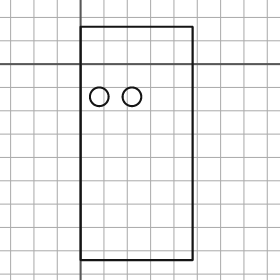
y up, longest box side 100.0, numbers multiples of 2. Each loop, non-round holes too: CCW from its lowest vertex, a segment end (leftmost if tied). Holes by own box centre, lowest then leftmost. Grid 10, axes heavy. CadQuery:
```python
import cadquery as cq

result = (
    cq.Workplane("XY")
    .moveTo(0.0, -84.0)
    .lineTo(48.0, -84.0)
    .lineTo(48.0, 16.0)
    .lineTo(0.0, 16.0)
    .close()
    .moveTo(8.0, -14.0)
    .circle(4.0)
    .moveTo(22.0, -14.0)
    .circle(4.0)
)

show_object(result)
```